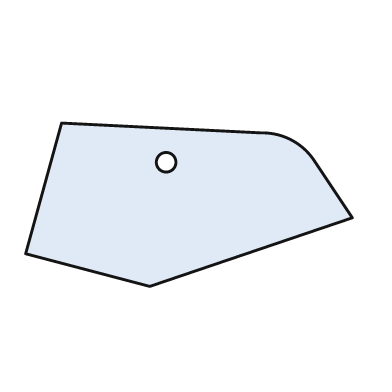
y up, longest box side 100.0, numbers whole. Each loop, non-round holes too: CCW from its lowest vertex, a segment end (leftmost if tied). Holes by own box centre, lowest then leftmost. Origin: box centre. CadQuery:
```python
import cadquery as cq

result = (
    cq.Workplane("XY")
    .moveTo(-12.0, -25.0)
    .lineTo(50.0, -4.0)
    .lineTo(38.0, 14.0)
    .threePointArc((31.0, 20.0), (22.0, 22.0))
    .lineTo(-39.0, 25.0)
    .lineTo(-50.0, -15.0)
    .close()
    .moveTo(-7.0, 13.0)
    .circle(3.0)
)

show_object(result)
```